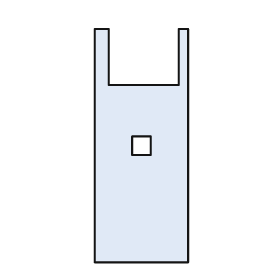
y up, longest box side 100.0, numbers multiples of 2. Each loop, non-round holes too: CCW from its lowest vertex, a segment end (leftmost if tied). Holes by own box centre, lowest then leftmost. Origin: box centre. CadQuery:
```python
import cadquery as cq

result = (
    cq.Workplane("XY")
    .moveTo(-20.0, -50.0)
    .lineTo(20.0, -50.0)
    .lineTo(20.0, 50.0)
    .lineTo(16.0, 50.0)
    .lineTo(16.0, 26.0)
    .lineTo(-14.0, 26.0)
    .lineTo(-14.0, 50.0)
    .lineTo(-20.0, 50.0)
    .close()
    .moveTo(-4.0, -4.0)
    .lineTo(4.0, -4.0)
    .lineTo(4.0, 4.0)
    .lineTo(-4.0, 4.0)
    .close()
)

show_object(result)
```